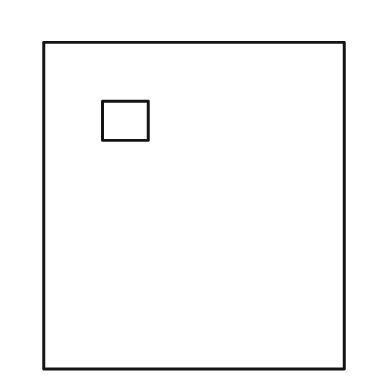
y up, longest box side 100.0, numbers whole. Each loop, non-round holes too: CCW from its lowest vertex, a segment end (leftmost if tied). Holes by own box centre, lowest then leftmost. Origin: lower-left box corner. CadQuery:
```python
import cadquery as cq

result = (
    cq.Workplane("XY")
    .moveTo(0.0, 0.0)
    .lineTo(92.0, 0.0)
    .lineTo(92.0, 100.0)
    .lineTo(0.0, 100.0)
    .close()
    .moveTo(18.0, 70.0)
    .lineTo(32.0, 70.0)
    .lineTo(32.0, 82.0)
    .lineTo(18.0, 82.0)
    .close()
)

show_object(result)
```